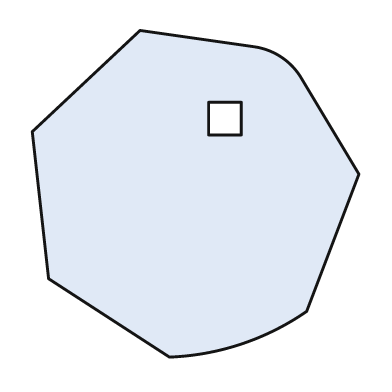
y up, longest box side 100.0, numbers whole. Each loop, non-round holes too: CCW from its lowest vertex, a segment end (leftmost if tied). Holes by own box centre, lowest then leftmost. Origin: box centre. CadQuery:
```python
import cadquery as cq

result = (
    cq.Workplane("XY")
    .moveTo(-8.0, -50.0)
    .threePointArc((14.0, -46.0), (34.0, -36.0))
    .lineTo(50.0, 6.0)
    .lineTo(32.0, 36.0)
    .threePointArc((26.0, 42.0), (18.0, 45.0))
    .lineTo(-17.0, 50.0)
    .lineTo(-50.0, 19.0)
    .lineTo(-45.0, -26.0)
    .close()
    .moveTo(4.0, 18.0)
    .lineTo(14.0, 18.0)
    .lineTo(14.0, 28.0)
    .lineTo(4.0, 28.0)
    .close()
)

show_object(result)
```